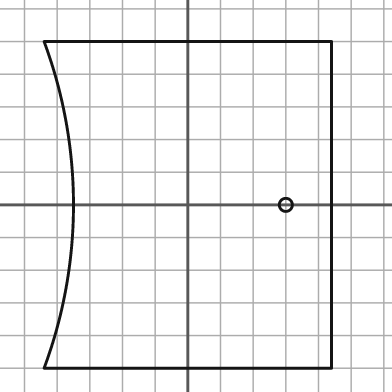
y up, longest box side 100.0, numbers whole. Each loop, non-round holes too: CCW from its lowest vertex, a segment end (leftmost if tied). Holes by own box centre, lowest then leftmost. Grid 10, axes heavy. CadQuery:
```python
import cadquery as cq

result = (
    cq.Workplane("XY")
    .moveTo(-44.0, -50.0)
    .lineTo(44.0, -50.0)
    .lineTo(44.0, 50.0)
    .lineTo(-44.0, 50.0)
    .threePointArc((-35.0, 0.0), (-44.0, -50.0))
    .close()
    .moveTo(30.0, 0.0)
    .circle(2.0)
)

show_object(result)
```